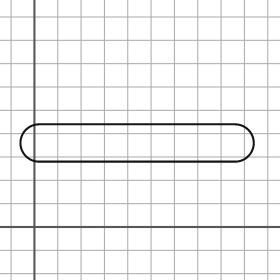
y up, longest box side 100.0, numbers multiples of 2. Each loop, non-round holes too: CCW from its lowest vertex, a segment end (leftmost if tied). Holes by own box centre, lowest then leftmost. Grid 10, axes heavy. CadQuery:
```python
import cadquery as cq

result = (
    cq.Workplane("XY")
    .moveTo(2.0, 28.0)
    .lineTo(86.0, 28.0)
    .threePointArc((94.0, 36.0), (86.0, 44.0))
    .lineTo(2.0, 44.0)
    .threePointArc((-6.0, 36.0), (2.0, 28.0))
    .close()
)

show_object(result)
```